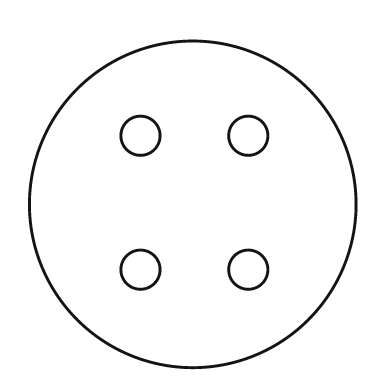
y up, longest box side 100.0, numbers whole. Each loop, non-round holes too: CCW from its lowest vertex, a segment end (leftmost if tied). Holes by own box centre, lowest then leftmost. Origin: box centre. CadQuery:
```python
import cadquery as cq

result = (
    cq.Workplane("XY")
    .moveTo(0.0, 0.0)
    .circle(50.0)
    .moveTo(-16.0, -20.0)
    .circle(6.0)
    .moveTo(17.0, -20.0)
    .circle(6.0)
    .moveTo(-16.0, 21.0)
    .circle(6.0)
    .moveTo(17.0, 21.0)
    .circle(6.0)
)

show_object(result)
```